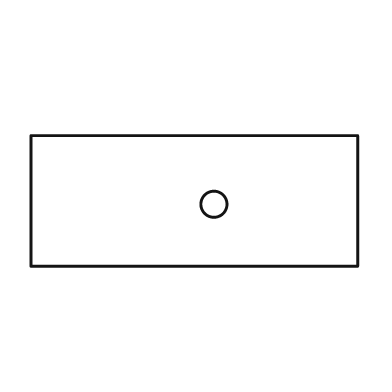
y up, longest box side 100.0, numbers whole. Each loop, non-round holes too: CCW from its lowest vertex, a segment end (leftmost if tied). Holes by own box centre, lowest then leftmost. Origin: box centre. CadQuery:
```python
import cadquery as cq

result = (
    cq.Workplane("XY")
    .moveTo(-50.0, -20.0)
    .lineTo(50.0, -20.0)
    .lineTo(50.0, 20.0)
    .lineTo(-50.0, 20.0)
    .close()
    .moveTo(6.0, -1.0)
    .circle(4.0)
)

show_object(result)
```